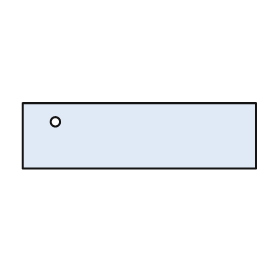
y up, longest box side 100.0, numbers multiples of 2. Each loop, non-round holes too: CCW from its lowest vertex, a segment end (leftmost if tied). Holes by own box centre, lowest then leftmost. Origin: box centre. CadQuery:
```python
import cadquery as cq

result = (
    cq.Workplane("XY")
    .moveTo(-50.0, -14.0)
    .lineTo(50.0, -14.0)
    .lineTo(50.0, 14.0)
    .lineTo(-50.0, 14.0)
    .close()
    .moveTo(-36.0, 6.0)
    .circle(2.0)
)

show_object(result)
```